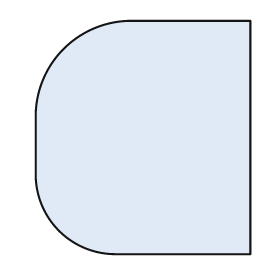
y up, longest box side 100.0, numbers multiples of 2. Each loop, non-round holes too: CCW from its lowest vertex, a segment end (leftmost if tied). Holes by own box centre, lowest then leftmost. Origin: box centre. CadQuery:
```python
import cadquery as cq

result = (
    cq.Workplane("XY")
    .moveTo(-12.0, -50.0)
    .lineTo(46.0, -50.0)
    .lineTo(46.0, 50.0)
    .lineTo(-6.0, 50.0)
    .threePointArc((-34.0, 38.0), (-46.0, 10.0))
    .lineTo(-46.0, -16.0)
    .threePointArc((-36.0, -40.0), (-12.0, -50.0))
    .close()
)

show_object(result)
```